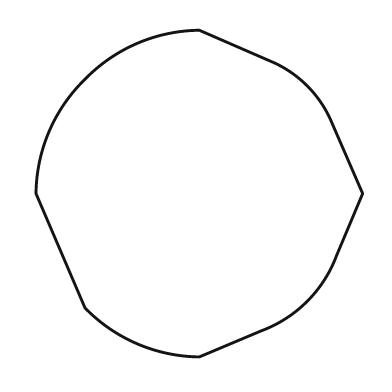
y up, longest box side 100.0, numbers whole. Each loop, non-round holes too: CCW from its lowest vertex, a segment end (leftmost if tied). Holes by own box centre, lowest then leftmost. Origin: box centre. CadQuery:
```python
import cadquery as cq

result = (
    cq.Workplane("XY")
    .moveTo(0.0, -50.0)
    .lineTo(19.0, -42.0)
    .threePointArc((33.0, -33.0), (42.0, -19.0))
    .lineTo(50.0, 0.0)
    .lineTo(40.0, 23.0)
    .threePointArc((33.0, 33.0), (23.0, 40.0))
    .lineTo(0.0, 50.0)
    .threePointArc((-19.0, 46.0), (-35.0, 35.0))
    .threePointArc((-46.0, 19.0), (-50.0, 0.0))
    .lineTo(-35.0, -35.0)
    .threePointArc((-19.0, -46.0), (0.0, -50.0))
    .close()
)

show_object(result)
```